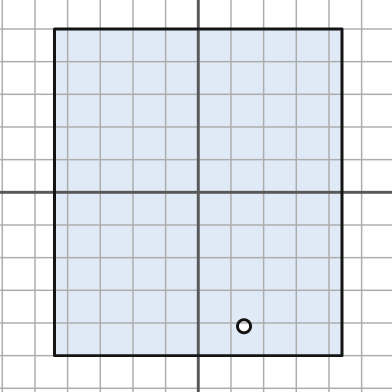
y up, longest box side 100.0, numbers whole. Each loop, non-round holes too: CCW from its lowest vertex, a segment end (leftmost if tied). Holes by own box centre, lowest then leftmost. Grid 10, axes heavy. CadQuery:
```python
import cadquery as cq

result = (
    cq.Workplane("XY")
    .moveTo(-44.0, -50.0)
    .lineTo(44.0, -50.0)
    .lineTo(44.0, 50.0)
    .lineTo(-44.0, 50.0)
    .close()
    .moveTo(14.0, -41.0)
    .circle(2.0)
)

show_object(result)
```